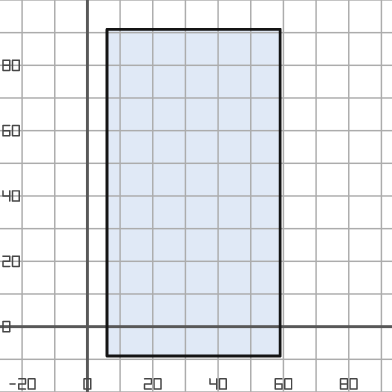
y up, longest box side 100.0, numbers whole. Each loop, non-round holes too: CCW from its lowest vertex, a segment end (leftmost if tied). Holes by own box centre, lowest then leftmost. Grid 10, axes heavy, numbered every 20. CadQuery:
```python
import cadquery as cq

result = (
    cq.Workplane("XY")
    .moveTo(6.0, -9.0)
    .lineTo(59.0, -9.0)
    .lineTo(59.0, 91.0)
    .lineTo(6.0, 91.0)
    .close()
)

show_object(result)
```